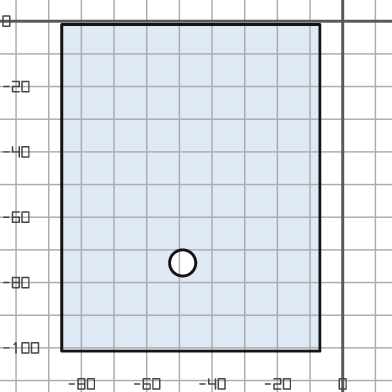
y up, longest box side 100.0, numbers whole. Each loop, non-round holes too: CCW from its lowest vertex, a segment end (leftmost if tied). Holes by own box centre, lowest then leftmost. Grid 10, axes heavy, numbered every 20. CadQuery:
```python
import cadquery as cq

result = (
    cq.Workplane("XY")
    .moveTo(-86.0, -101.0)
    .lineTo(-7.0, -101.0)
    .lineTo(-7.0, -1.0)
    .lineTo(-86.0, -1.0)
    .close()
    .moveTo(-49.0, -74.0)
    .circle(4.0)
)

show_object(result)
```